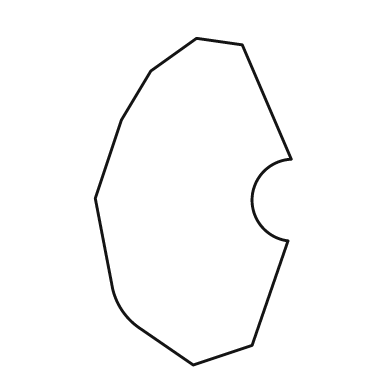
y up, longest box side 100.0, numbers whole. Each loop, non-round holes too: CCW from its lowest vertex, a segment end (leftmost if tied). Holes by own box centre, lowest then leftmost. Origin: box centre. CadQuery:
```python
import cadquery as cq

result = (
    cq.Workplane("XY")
    .moveTo(0.0, -50.0)
    .lineTo(18.0, -44.0)
    .lineTo(29.0, -12.0)
    .threePointArc((18.0, 1.0), (30.0, 13.0))
    .lineTo(15.0, 48.0)
    .lineTo(1.0, 50.0)
    .lineTo(-13.0, 40.0)
    .lineTo(-22.0, 25.0)
    .lineTo(-30.0, 1.0)
    .lineTo(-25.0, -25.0)
    .threePointArc((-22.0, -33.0), (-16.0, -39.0))
    .close()
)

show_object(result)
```